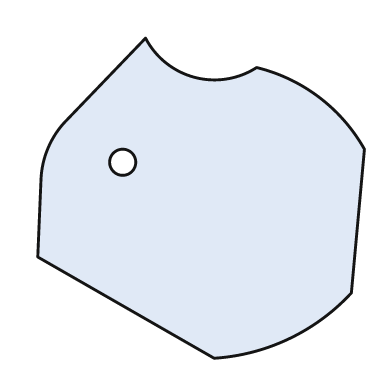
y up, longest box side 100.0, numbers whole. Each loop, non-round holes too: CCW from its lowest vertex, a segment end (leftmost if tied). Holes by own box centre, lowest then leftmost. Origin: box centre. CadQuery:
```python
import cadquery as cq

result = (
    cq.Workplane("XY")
    .moveTo(4.0, -49.0)
    .threePointArc((27.0, -43.0), (46.0, -29.0))
    .lineTo(50.0, 15.0)
    .threePointArc((36.0, 31.0), (17.0, 40.0))
    .threePointArc((-2.0, 37.0), (-17.0, 49.0))
    .lineTo(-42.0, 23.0)
    .threePointArc((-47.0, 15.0), (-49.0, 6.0))
    .lineTo(-50.0, -18.0)
    .close()
    .moveTo(-24.0, 11.0)
    .circle(4.0)
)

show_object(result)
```